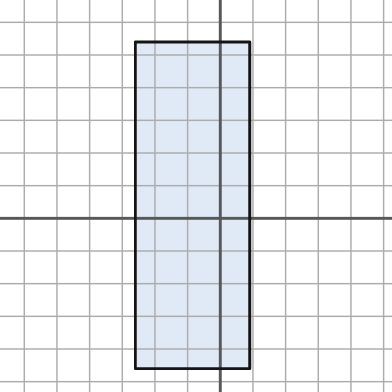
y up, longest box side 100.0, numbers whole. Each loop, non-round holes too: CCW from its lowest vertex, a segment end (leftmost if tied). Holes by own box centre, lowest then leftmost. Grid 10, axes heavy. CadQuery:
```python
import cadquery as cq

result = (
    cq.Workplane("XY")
    .moveTo(-26.0, -46.0)
    .lineTo(9.0, -46.0)
    .lineTo(9.0, 54.0)
    .lineTo(-26.0, 54.0)
    .close()
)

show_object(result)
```